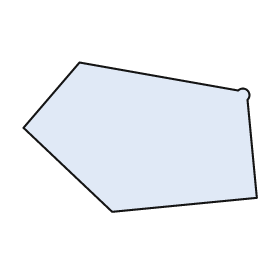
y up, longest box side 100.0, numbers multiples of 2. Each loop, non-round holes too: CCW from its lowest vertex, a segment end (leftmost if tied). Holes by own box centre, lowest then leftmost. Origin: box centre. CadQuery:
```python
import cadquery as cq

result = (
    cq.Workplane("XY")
    .moveTo(-12.0, -32.0)
    .lineTo(50.0, -26.0)
    .lineTo(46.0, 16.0)
    .threePointArc((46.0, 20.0), (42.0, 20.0))
    .lineTo(-26.0, 32.0)
    .lineTo(-50.0, 4.0)
    .close()
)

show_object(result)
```